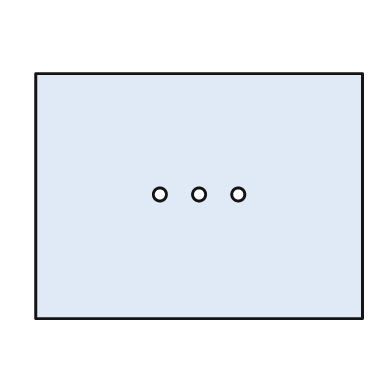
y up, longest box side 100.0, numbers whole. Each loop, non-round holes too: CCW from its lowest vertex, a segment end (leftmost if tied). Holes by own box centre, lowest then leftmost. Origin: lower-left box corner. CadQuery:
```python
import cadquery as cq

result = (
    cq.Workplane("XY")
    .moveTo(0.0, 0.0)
    .lineTo(100.0, 0.0)
    .lineTo(100.0, 75.0)
    .lineTo(0.0, 75.0)
    .close()
    .moveTo(38.0, 38.0)
    .circle(2.0)
    .moveTo(50.0, 38.0)
    .circle(2.0)
    .moveTo(62.0, 38.0)
    .circle(2.0)
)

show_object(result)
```